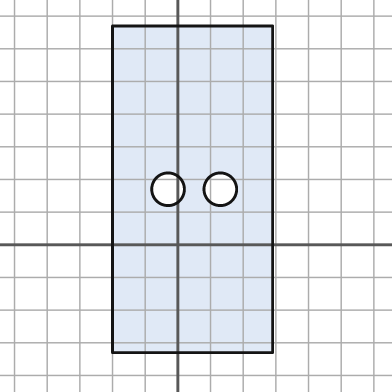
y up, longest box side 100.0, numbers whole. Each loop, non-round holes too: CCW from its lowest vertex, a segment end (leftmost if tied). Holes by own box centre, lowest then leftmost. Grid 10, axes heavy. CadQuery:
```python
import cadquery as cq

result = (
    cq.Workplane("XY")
    .moveTo(-20.0, -33.0)
    .lineTo(29.0, -33.0)
    .lineTo(29.0, 67.0)
    .lineTo(-20.0, 67.0)
    .close()
    .moveTo(-3.0, 17.0)
    .circle(5.0)
    .moveTo(13.0, 17.0)
    .circle(5.0)
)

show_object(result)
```